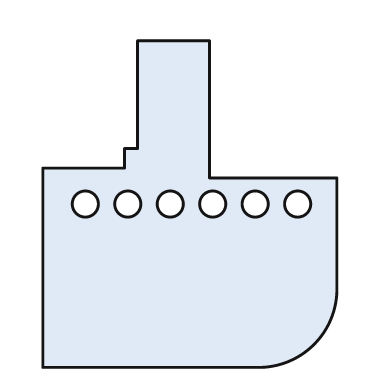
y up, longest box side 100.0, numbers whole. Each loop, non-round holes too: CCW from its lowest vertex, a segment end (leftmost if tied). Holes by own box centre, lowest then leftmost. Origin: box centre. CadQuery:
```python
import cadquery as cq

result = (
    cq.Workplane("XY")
    .moveTo(-45.0, -50.0)
    .lineTo(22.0, -50.0)
    .threePointArc((38.0, -43.0), (45.0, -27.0))
    .lineTo(45.0, 8.0)
    .lineTo(6.0, 8.0)
    .lineTo(6.0, 50.0)
    .lineTo(-16.0, 50.0)
    .lineTo(-16.0, 17.0)
    .lineTo(-20.0, 17.0)
    .lineTo(-20.0, 11.0)
    .lineTo(-45.0, 11.0)
    .close()
    .moveTo(-32.0, 0.0)
    .circle(4.0)
    .moveTo(-19.0, 0.0)
    .circle(4.0)
    .moveTo(-6.0, 0.0)
    .circle(4.0)
    .moveTo(7.0, 0.0)
    .circle(4.0)
    .moveTo(20.0, 0.0)
    .circle(4.0)
    .moveTo(33.0, 0.0)
    .circle(4.0)
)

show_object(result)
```